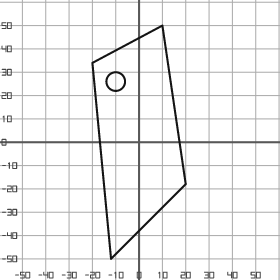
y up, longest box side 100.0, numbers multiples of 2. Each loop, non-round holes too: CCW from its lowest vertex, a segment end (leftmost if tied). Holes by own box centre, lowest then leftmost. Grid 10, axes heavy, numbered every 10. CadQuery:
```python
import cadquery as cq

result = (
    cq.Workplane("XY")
    .moveTo(-12.0, -50.0)
    .lineTo(20.0, -18.0)
    .lineTo(10.0, 50.0)
    .lineTo(-20.0, 34.0)
    .close()
    .moveTo(-10.0, 26.0)
    .circle(4.0)
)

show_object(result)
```